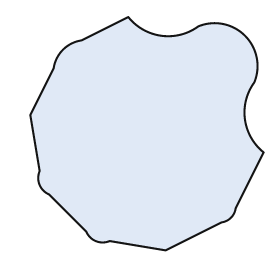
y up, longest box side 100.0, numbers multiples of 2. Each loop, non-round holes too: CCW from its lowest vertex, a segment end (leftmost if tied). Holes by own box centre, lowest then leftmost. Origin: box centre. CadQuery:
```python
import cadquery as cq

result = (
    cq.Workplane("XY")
    .moveTo(8.0, -50.0)
    .lineTo(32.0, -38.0)
    .threePointArc((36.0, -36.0), (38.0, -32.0))
    .lineTo(50.0, -8.0)
    .threePointArc((42.0, 6.0), (46.0, 22.0))
    .threePointArc((42.0, 42.0), (22.0, 46.0))
    .threePointArc((6.0, 42.0), (-8.0, 50.0))
    .lineTo(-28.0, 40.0)
    .threePointArc((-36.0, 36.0), (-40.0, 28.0))
    .lineTo(-50.0, 8.0)
    .lineTo(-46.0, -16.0)
    .threePointArc((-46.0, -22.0), (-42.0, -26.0))
    .lineTo(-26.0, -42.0)
    .threePointArc((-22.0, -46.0), (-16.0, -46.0))
    .close()
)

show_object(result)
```